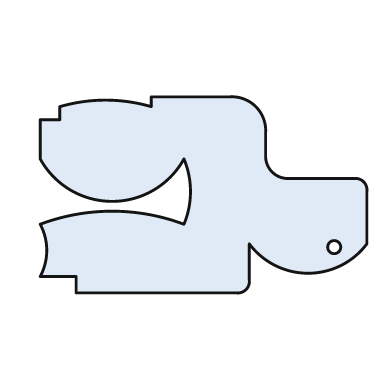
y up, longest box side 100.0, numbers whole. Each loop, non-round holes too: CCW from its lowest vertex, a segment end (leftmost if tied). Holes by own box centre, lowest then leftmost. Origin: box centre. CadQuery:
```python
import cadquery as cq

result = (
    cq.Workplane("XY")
    .moveTo(-39.0, -30.0)
    .lineTo(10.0, -30.0)
    .threePointArc((13.0, -29.0), (14.0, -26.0))
    .lineTo(14.0, -15.0)
    .threePointArc((32.0, -24.0), (50.0, -15.0))
    .lineTo(50.0, 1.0)
    .threePointArc((49.0, 4.0), (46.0, 5.0))
    .lineTo(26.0, 5.0)
    .threePointArc((21.0, 7.0), (19.0, 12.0))
    .lineTo(19.0, 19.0)
    .threePointArc((16.0, 27.0), (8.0, 30.0))
    .lineTo(-16.0, 30.0)
    .lineTo(-16.0, 27.0)
    .threePointArc((-30.0, 29.0), (-44.0, 27.0))
    .lineTo(-44.0, 23.0)
    .lineTo(-50.0, 23.0)
    .lineTo(-50.0, 11.0)
    .threePointArc((-28.0, -2.0), (-6.0, 11.0))
    .threePointArc((-4.0, 1.0), (-6.0, -9.0))
    .threePointArc((-28.0, -5.0), (-50.0, -9.0))
    .threePointArc((-48.0, -17.0), (-50.0, -25.0))
    .lineTo(-39.0, -25.0)
    .close()
    .moveTo(40.0, -16.0)
    .circle(2.0)
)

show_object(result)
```